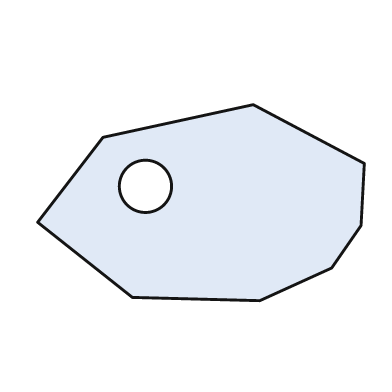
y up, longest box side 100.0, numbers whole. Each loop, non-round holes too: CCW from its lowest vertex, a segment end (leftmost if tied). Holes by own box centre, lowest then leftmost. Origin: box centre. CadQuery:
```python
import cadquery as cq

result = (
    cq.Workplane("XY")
    .moveTo(18.0, -30.0)
    .lineTo(40.0, -20.0)
    .lineTo(49.0, -7.0)
    .lineTo(50.0, 12.0)
    .lineTo(16.0, 30.0)
    .lineTo(-30.0, 20.0)
    .lineTo(-50.0, -6.0)
    .lineTo(-21.0, -29.0)
    .close()
    .moveTo(-17.0, 5.0)
    .circle(8.0)
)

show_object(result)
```